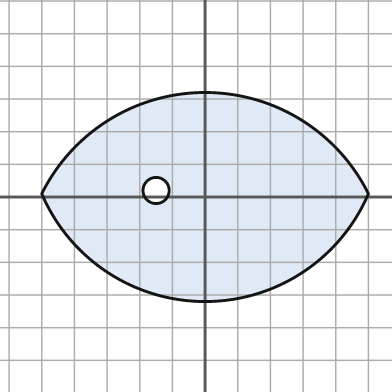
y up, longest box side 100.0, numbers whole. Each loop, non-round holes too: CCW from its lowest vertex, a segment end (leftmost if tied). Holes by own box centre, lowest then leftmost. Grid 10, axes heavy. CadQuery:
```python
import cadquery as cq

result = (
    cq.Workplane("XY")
    .moveTo(-50.0, 1.0)
    .threePointArc((0.0, -32.0), (50.0, 1.0))
    .threePointArc((0.0, 32.0), (-50.0, 1.0))
    .close()
    .moveTo(-15.0, 2.0)
    .circle(4.0)
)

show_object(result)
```